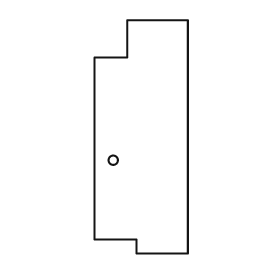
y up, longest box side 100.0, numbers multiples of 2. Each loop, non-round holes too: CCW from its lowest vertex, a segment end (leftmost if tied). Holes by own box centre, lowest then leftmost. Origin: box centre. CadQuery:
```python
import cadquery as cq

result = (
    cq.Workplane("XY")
    .moveTo(-2.0, -50.0)
    .lineTo(20.0, -50.0)
    .lineTo(20.0, 50.0)
    .lineTo(-6.0, 50.0)
    .lineTo(-6.0, 34.0)
    .lineTo(-20.0, 34.0)
    .lineTo(-20.0, -44.0)
    .lineTo(-2.0, -44.0)
    .close()
    .moveTo(-12.0, -10.0)
    .circle(2.0)
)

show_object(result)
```